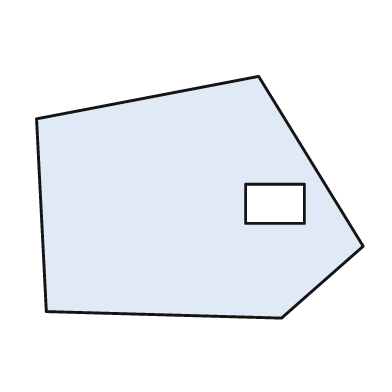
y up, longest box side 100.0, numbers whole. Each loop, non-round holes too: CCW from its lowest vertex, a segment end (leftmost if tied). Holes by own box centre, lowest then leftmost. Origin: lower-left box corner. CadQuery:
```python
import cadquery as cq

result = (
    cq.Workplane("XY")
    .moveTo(75.0, 0.0)
    .lineTo(100.0, 22.0)
    .lineTo(68.0, 74.0)
    .lineTo(0.0, 61.0)
    .lineTo(3.0, 2.0)
    .close()
    .moveTo(64.0, 29.0)
    .lineTo(82.0, 29.0)
    .lineTo(82.0, 41.0)
    .lineTo(64.0, 41.0)
    .close()
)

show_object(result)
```